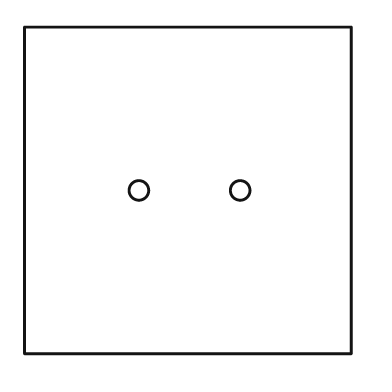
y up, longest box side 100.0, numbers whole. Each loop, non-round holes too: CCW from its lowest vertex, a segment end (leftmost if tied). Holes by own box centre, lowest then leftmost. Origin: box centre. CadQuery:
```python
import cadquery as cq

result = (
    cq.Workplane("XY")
    .moveTo(-50.0, -50.0)
    .lineTo(50.0, -50.0)
    .lineTo(50.0, 50.0)
    .lineTo(-50.0, 50.0)
    .close()
    .moveTo(-15.0, 0.0)
    .circle(3.0)
    .moveTo(16.0, 0.0)
    .circle(3.0)
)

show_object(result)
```